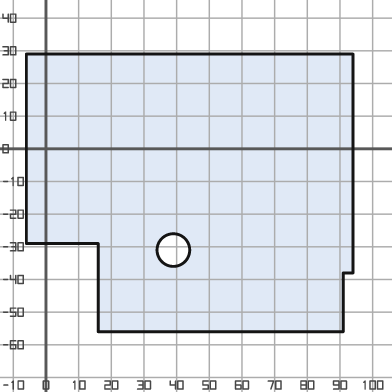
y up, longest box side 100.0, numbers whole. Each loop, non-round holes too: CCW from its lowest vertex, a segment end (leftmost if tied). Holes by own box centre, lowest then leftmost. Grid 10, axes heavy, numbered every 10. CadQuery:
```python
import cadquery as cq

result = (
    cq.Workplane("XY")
    .moveTo(16.0, -56.0)
    .lineTo(91.0, -56.0)
    .lineTo(91.0, -38.0)
    .lineTo(94.0, -38.0)
    .lineTo(94.0, 29.0)
    .lineTo(-6.0, 29.0)
    .lineTo(-6.0, -29.0)
    .lineTo(16.0, -29.0)
    .close()
    .moveTo(39.0, -31.0)
    .circle(5.0)
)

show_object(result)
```